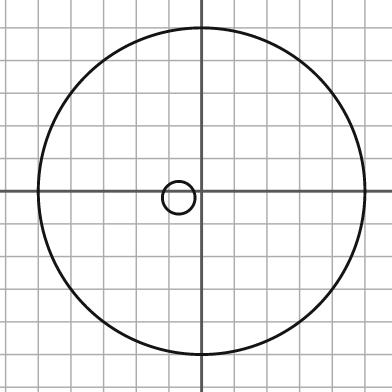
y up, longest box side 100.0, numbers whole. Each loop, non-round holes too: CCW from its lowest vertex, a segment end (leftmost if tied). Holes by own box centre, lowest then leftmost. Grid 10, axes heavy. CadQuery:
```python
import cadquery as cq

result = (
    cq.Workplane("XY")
    .moveTo(0.0, 0.0)
    .circle(50.0)
    .moveTo(-7.0, -2.0)
    .circle(5.0)
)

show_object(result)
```